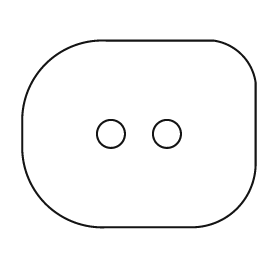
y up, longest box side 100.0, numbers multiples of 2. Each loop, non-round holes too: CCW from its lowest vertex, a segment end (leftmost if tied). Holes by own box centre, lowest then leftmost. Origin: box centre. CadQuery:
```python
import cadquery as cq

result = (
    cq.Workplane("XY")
    .moveTo(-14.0, -40.0)
    .lineTo(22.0, -40.0)
    .threePointArc((42.0, -32.0), (50.0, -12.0))
    .lineTo(50.0, 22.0)
    .threePointArc((44.0, 34.0), (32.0, 40.0))
    .lineTo(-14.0, 40.0)
    .threePointArc((-40.0, 30.0), (-50.0, 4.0))
    .lineTo(-50.0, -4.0)
    .threePointArc((-40.0, -30.0), (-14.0, -40.0))
    .close()
    .moveTo(-12.0, 0.0)
    .circle(6.0)
    .moveTo(12.0, 0.0)
    .circle(6.0)
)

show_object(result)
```